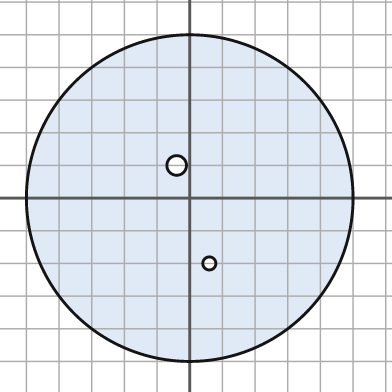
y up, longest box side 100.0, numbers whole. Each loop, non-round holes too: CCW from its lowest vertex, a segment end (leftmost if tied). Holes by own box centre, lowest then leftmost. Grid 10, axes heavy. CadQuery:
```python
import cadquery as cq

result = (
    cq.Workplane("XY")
    .moveTo(0.0, 0.0)
    .circle(50.0)
    .moveTo(6.0, -20.0)
    .circle(2.0)
    .moveTo(-4.0, 10.0)
    .circle(3.0)
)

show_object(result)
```